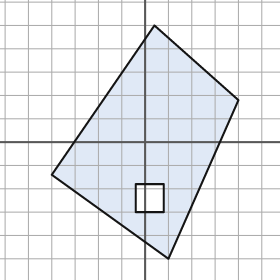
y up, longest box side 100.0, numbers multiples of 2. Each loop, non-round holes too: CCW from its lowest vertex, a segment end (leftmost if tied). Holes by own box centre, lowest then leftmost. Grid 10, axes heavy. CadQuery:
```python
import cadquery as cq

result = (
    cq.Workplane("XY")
    .moveTo(10.0, -50.0)
    .lineTo(40.0, 18.0)
    .lineTo(4.0, 50.0)
    .lineTo(-40.0, -14.0)
    .close()
    .moveTo(-4.0, -30.0)
    .lineTo(8.0, -30.0)
    .lineTo(8.0, -18.0)
    .lineTo(-4.0, -18.0)
    .close()
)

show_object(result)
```